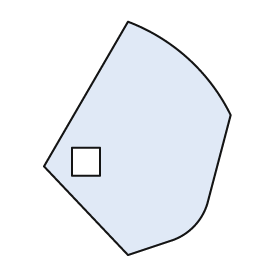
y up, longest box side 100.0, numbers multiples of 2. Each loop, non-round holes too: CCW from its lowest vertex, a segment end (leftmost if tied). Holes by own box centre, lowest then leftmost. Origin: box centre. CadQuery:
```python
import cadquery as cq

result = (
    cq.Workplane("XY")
    .moveTo(-4.0, -50.0)
    .lineTo(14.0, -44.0)
    .threePointArc((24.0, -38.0), (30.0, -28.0))
    .lineTo(40.0, 10.0)
    .threePointArc((22.0, 34.0), (-4.0, 50.0))
    .lineTo(-40.0, -12.0)
    .close()
    .moveTo(-28.0, -16.0)
    .lineTo(-16.0, -16.0)
    .lineTo(-16.0, -4.0)
    .lineTo(-28.0, -4.0)
    .close()
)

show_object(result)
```